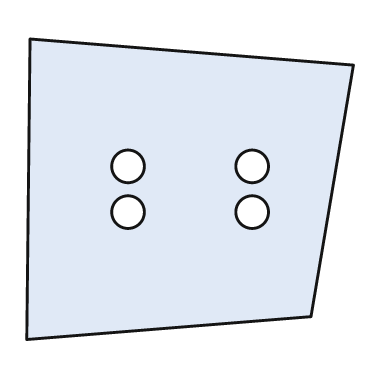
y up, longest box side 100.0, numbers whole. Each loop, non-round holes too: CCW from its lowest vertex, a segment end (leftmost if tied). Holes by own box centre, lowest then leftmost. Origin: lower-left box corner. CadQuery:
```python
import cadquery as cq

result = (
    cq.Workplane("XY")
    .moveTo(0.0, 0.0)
    .lineTo(87.0, 7.0)
    .lineTo(100.0, 84.0)
    .lineTo(1.0, 92.0)
    .close()
    .moveTo(31.0, 39.0)
    .circle(5.0)
    .moveTo(69.0, 39.0)
    .circle(5.0)
    .moveTo(31.0, 53.0)
    .circle(5.0)
    .moveTo(69.0, 53.0)
    .circle(5.0)
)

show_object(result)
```